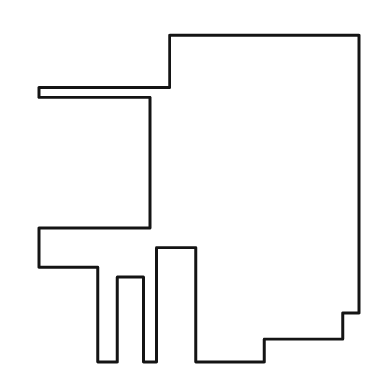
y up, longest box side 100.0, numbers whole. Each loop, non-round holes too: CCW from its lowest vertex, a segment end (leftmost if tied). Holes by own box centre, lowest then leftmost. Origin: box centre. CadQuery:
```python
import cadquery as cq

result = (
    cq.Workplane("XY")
    .moveTo(-31.0, -50.0)
    .lineTo(-25.0, -50.0)
    .lineTo(-25.0, -24.0)
    .lineTo(-17.0, -24.0)
    .lineTo(-17.0, -50.0)
    .lineTo(-13.0, -50.0)
    .lineTo(-13.0, -15.0)
    .lineTo(-1.0, -15.0)
    .lineTo(-1.0, -50.0)
    .lineTo(20.0, -50.0)
    .lineTo(20.0, -43.0)
    .lineTo(44.0, -43.0)
    .lineTo(44.0, -35.0)
    .lineTo(49.0, -35.0)
    .lineTo(49.0, 50.0)
    .lineTo(-9.0, 50.0)
    .lineTo(-9.0, 34.0)
    .lineTo(-49.0, 34.0)
    .lineTo(-49.0, 31.0)
    .lineTo(-15.0, 31.0)
    .lineTo(-15.0, -9.0)
    .lineTo(-49.0, -9.0)
    .lineTo(-49.0, -21.0)
    .lineTo(-31.0, -21.0)
    .close()
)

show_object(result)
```